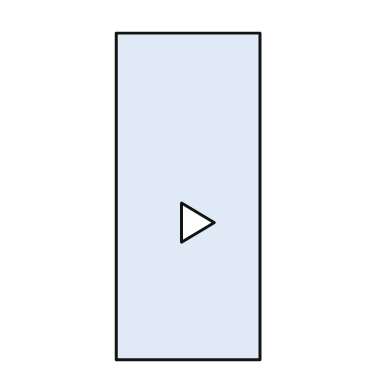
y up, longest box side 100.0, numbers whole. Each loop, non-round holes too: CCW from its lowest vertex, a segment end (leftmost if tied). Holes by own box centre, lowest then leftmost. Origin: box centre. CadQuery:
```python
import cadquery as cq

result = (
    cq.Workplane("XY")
    .moveTo(-22.0, -50.0)
    .lineTo(22.0, -50.0)
    .lineTo(22.0, 50.0)
    .lineTo(-22.0, 50.0)
    .close()
    .moveTo(-2.0, -14.0)
    .lineTo(8.0, -8.0)
    .lineTo(-2.0, -2.0)
    .close()
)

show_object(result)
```